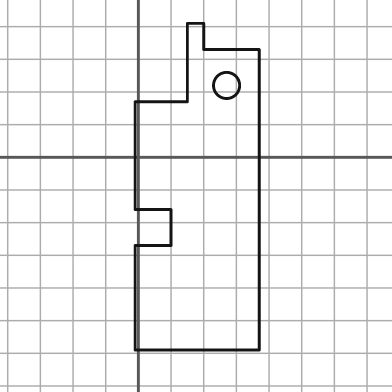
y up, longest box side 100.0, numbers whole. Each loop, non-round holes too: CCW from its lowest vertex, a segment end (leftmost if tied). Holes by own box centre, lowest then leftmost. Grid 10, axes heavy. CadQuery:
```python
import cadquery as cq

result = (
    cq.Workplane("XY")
    .moveTo(-1.0, -59.0)
    .lineTo(37.0, -59.0)
    .lineTo(37.0, 33.0)
    .lineTo(20.0, 33.0)
    .lineTo(20.0, 41.0)
    .lineTo(15.0, 41.0)
    .lineTo(15.0, 17.0)
    .lineTo(-1.0, 17.0)
    .lineTo(-1.0, -16.0)
    .lineTo(10.0, -16.0)
    .lineTo(10.0, -27.0)
    .lineTo(-1.0, -27.0)
    .close()
    .moveTo(27.0, 22.0)
    .circle(4.0)
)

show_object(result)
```